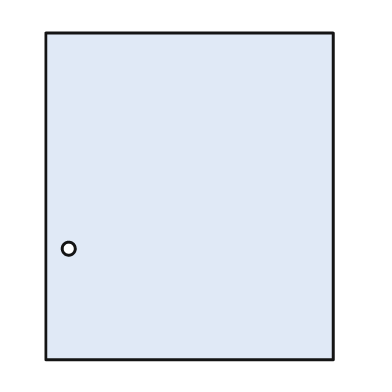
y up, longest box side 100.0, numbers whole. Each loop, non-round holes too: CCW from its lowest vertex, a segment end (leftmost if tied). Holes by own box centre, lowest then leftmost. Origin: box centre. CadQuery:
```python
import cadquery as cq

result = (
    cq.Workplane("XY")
    .moveTo(-44.0, -50.0)
    .lineTo(44.0, -50.0)
    .lineTo(44.0, 50.0)
    .lineTo(-44.0, 50.0)
    .close()
    .moveTo(-37.0, -16.0)
    .circle(2.0)
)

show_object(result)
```